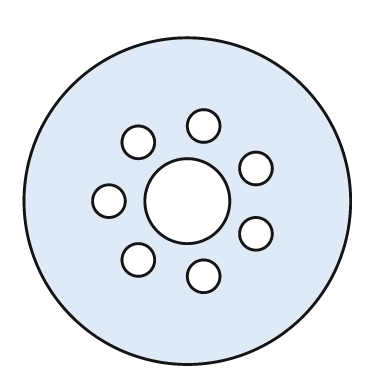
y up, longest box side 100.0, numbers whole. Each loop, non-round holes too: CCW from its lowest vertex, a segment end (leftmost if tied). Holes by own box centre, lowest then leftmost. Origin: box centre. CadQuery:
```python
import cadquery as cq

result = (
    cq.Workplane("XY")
    .moveTo(0.0, 0.0)
    .circle(50.0)
    .moveTo(5.0, -23.0)
    .circle(5.0)
    .moveTo(-15.0, -18.0)
    .circle(5.0)
    .moveTo(21.0, -10.0)
    .circle(5.0)
    .moveTo(-24.0, 0.0)
    .circle(5.0)
    .moveTo(0.0, 0.0)
    .circle(13.0)
    .moveTo(21.0, 10.0)
    .circle(5.0)
    .moveTo(-15.0, 18.0)
    .circle(5.0)
    .moveTo(5.0, 23.0)
    .circle(5.0)
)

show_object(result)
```